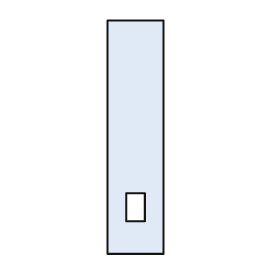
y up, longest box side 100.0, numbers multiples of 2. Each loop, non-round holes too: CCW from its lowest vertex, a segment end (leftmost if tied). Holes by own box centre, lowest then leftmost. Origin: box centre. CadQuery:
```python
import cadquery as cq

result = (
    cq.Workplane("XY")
    .moveTo(-12.0, -50.0)
    .lineTo(12.0, -50.0)
    .lineTo(12.0, 50.0)
    .lineTo(-12.0, 50.0)
    .close()
    .moveTo(-4.0, -36.0)
    .lineTo(4.0, -36.0)
    .lineTo(4.0, -24.0)
    .lineTo(-4.0, -24.0)
    .close()
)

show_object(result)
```